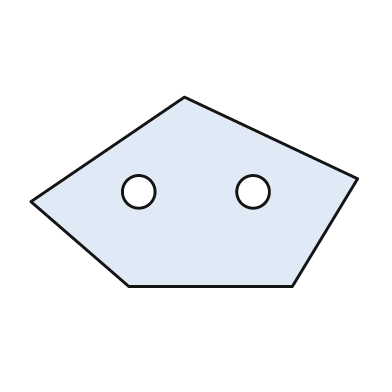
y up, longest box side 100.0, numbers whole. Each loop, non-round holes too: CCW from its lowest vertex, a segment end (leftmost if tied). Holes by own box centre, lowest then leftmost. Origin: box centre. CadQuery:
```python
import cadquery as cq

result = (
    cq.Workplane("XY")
    .moveTo(-20.0, -29.0)
    .lineTo(30.0, -29.0)
    .lineTo(50.0, 4.0)
    .lineTo(-3.0, 29.0)
    .lineTo(-50.0, -3.0)
    .close()
    .moveTo(-17.0, 0.0)
    .circle(5.0)
    .moveTo(18.0, 0.0)
    .circle(5.0)
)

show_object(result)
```